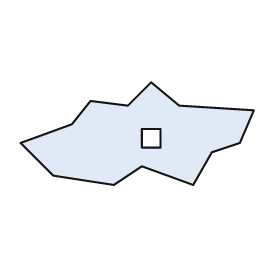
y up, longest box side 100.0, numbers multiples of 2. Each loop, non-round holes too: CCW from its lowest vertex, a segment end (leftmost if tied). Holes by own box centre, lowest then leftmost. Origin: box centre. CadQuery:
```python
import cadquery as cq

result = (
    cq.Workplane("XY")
    .moveTo(-10.0, -22.0)
    .lineTo(2.0, -14.0)
    .lineTo(24.0, -22.0)
    .lineTo(32.0, -8.0)
    .lineTo(44.0, -4.0)
    .lineTo(50.0, 10.0)
    .lineTo(18.0, 12.0)
    .lineTo(6.0, 22.0)
    .lineTo(-4.0, 12.0)
    .lineTo(-20.0, 14.0)
    .lineTo(-28.0, 4.0)
    .lineTo(-50.0, -4.0)
    .lineTo(-36.0, -18.0)
    .close()
    .moveTo(2.0, -6.0)
    .lineTo(10.0, -6.0)
    .lineTo(10.0, 2.0)
    .lineTo(2.0, 2.0)
    .close()
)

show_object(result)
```